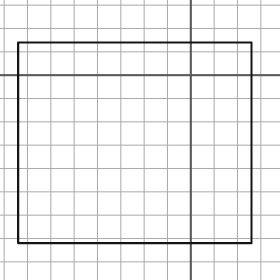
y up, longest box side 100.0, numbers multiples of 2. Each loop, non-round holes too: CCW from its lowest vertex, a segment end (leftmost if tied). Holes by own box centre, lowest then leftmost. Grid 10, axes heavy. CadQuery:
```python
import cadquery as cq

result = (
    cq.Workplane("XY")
    .moveTo(-74.0, -72.0)
    .lineTo(26.0, -72.0)
    .lineTo(26.0, 14.0)
    .lineTo(-74.0, 14.0)
    .close()
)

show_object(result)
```